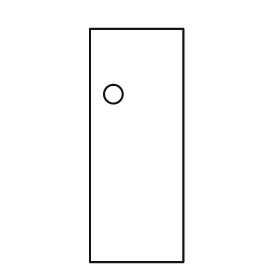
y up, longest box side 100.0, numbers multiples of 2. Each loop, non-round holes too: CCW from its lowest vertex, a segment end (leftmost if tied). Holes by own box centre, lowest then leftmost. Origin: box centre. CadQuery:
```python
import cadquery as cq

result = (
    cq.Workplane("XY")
    .moveTo(-20.0, -50.0)
    .lineTo(20.0, -50.0)
    .lineTo(20.0, 50.0)
    .lineTo(-20.0, 50.0)
    .close()
    .moveTo(-10.0, 22.0)
    .circle(4.0)
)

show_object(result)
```